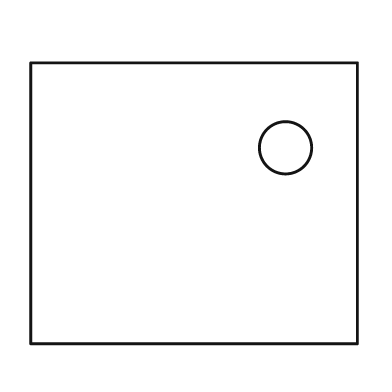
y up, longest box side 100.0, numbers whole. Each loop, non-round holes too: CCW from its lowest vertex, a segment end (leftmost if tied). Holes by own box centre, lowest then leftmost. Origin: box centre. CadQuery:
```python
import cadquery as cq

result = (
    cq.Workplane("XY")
    .moveTo(-50.0, -43.0)
    .lineTo(50.0, -43.0)
    .lineTo(50.0, 43.0)
    .lineTo(-50.0, 43.0)
    .close()
    .moveTo(28.0, 17.0)
    .circle(8.0)
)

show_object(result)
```